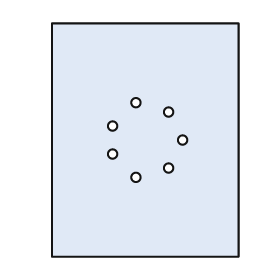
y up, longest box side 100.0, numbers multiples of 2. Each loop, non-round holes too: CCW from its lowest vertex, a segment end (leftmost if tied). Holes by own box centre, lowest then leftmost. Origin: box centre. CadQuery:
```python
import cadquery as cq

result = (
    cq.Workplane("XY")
    .moveTo(-40.0, -50.0)
    .lineTo(40.0, -50.0)
    .lineTo(40.0, 50.0)
    .lineTo(-40.0, 50.0)
    .close()
    .moveTo(-4.0, -16.0)
    .circle(2.0)
    .moveTo(10.0, -12.0)
    .circle(2.0)
    .moveTo(-14.0, -6.0)
    .circle(2.0)
    .moveTo(16.0, 0.0)
    .circle(2.0)
    .moveTo(-14.0, 6.0)
    .circle(2.0)
    .moveTo(10.0, 12.0)
    .circle(2.0)
    .moveTo(-4.0, 16.0)
    .circle(2.0)
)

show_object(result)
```